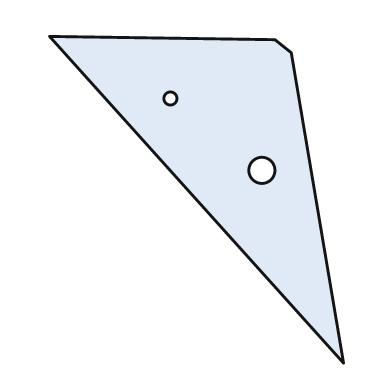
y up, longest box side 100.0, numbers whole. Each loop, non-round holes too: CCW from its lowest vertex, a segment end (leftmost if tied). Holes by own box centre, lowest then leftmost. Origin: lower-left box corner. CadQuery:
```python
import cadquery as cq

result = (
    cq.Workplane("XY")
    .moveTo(90.0, 0.0)
    .lineTo(74.0, 95.0)
    .lineTo(69.0, 99.0)
    .lineTo(0.0, 100.0)
    .close()
    .moveTo(65.0, 59.0)
    .circle(4.0)
    .moveTo(37.0, 81.0)
    .circle(2.0)
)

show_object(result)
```